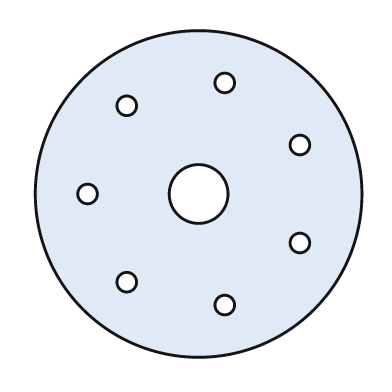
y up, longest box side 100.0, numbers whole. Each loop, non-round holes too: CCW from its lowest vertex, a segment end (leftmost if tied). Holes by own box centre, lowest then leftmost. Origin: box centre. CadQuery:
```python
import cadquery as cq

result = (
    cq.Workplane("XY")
    .moveTo(0.0, 0.0)
    .circle(50.0)
    .moveTo(8.0, -34.0)
    .circle(3.0)
    .moveTo(-22.0, -27.0)
    .circle(3.0)
    .moveTo(31.0, -15.0)
    .circle(3.0)
    .moveTo(-34.0, 0.0)
    .circle(3.0)
    .moveTo(0.0, 0.0)
    .circle(9.0)
    .moveTo(31.0, 15.0)
    .circle(3.0)
    .moveTo(-22.0, 27.0)
    .circle(3.0)
    .moveTo(8.0, 34.0)
    .circle(3.0)
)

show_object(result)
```